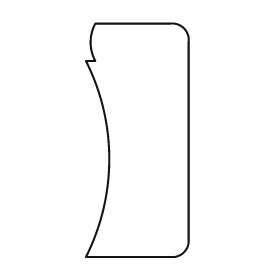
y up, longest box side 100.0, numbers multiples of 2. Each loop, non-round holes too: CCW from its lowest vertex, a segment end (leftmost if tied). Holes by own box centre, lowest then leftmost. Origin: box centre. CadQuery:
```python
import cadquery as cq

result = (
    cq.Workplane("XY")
    .moveTo(-22.0, -50.0)
    .lineTo(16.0, -50.0)
    .threePointArc((20.0, -48.0), (22.0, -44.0))
    .lineTo(22.0, 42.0)
    .threePointArc((20.0, 48.0), (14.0, 50.0))
    .lineTo(-18.0, 50.0)
    .threePointArc((-20.0, 42.0), (-18.0, 34.0))
    .lineTo(-22.0, 34.0)
    .threePointArc((-12.0, -8.0), (-22.0, -50.0))
    .close()
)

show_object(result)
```